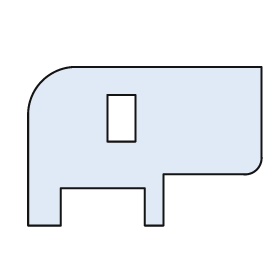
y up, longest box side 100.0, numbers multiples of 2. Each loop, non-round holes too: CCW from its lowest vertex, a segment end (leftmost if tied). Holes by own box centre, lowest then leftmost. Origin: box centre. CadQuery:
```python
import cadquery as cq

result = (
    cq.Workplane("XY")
    .moveTo(-50.0, -34.0)
    .lineTo(-36.0, -34.0)
    .lineTo(-36.0, -18.0)
    .lineTo(0.0, -18.0)
    .lineTo(0.0, -34.0)
    .lineTo(8.0, -34.0)
    .lineTo(8.0, -12.0)
    .lineTo(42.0, -12.0)
    .threePointArc((48.0, -10.0), (50.0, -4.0))
    .lineTo(50.0, 34.0)
    .lineTo(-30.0, 34.0)
    .threePointArc((-44.0, 28.0), (-50.0, 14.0))
    .close()
    .moveTo(-16.0, 2.0)
    .lineTo(-4.0, 2.0)
    .lineTo(-4.0, 22.0)
    .lineTo(-16.0, 22.0)
    .close()
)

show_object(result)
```